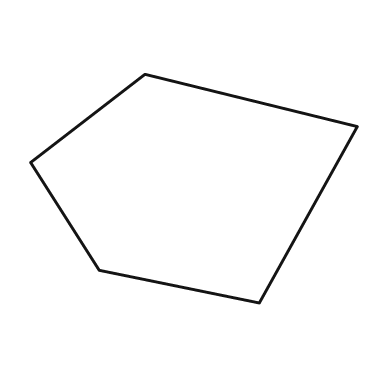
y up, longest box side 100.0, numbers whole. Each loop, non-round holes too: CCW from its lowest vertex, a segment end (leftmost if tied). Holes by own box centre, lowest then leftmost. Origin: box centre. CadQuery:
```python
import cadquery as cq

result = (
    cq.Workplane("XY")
    .moveTo(20.0, -35.0)
    .lineTo(50.0, 19.0)
    .lineTo(-15.0, 35.0)
    .lineTo(-50.0, 8.0)
    .lineTo(-29.0, -25.0)
    .close()
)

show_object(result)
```